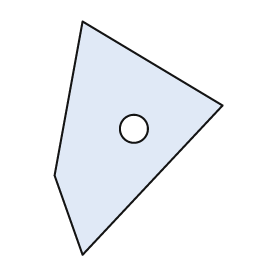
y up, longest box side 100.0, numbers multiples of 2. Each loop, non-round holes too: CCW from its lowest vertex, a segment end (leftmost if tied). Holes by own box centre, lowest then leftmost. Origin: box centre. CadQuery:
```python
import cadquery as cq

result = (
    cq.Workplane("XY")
    .moveTo(-24.0, -50.0)
    .lineTo(36.0, 14.0)
    .lineTo(-24.0, 50.0)
    .lineTo(-36.0, -16.0)
    .close()
    .moveTo(-2.0, 4.0)
    .circle(6.0)
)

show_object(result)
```